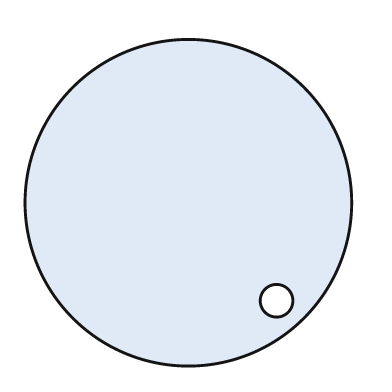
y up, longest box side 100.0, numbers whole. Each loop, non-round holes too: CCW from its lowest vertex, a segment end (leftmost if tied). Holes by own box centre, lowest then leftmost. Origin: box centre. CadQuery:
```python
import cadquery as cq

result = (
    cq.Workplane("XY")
    .moveTo(0.0, 0.0)
    .circle(50.0)
    .moveTo(27.0, -30.0)
    .circle(5.0)
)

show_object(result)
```